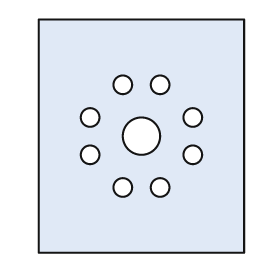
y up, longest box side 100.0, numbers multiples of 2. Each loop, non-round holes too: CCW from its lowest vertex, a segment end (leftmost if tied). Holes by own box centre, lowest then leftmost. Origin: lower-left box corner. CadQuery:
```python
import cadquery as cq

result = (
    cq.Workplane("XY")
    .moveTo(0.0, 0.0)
    .lineTo(88.0, 0.0)
    .lineTo(88.0, 100.0)
    .lineTo(0.0, 100.0)
    .close()
    .moveTo(36.0, 28.0)
    .circle(4.0)
    .moveTo(52.0, 28.0)
    .circle(4.0)
    .moveTo(22.0, 42.0)
    .circle(4.0)
    .moveTo(66.0, 42.0)
    .circle(4.0)
    .moveTo(44.0, 50.0)
    .circle(8.0)
    .moveTo(22.0, 58.0)
    .circle(4.0)
    .moveTo(66.0, 58.0)
    .circle(4.0)
    .moveTo(36.0, 72.0)
    .circle(4.0)
    .moveTo(52.0, 72.0)
    .circle(4.0)
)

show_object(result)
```